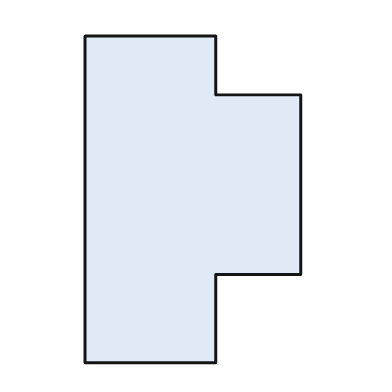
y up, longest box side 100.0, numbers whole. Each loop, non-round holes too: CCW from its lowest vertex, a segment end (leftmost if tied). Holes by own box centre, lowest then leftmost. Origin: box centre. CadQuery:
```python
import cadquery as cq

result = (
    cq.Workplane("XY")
    .moveTo(-33.0, -50.0)
    .lineTo(7.0, -50.0)
    .lineTo(7.0, -23.0)
    .lineTo(33.0, -23.0)
    .lineTo(33.0, 32.0)
    .lineTo(7.0, 32.0)
    .lineTo(7.0, 50.0)
    .lineTo(-33.0, 50.0)
    .close()
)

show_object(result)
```